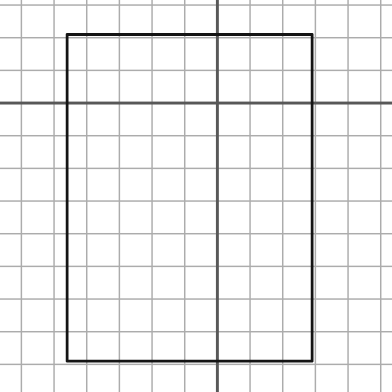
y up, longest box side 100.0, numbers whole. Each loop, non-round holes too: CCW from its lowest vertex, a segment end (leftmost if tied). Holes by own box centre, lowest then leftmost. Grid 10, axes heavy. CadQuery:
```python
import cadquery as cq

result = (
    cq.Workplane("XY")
    .moveTo(-46.0, -79.0)
    .lineTo(29.0, -79.0)
    .lineTo(29.0, 21.0)
    .lineTo(-46.0, 21.0)
    .close()
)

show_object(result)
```